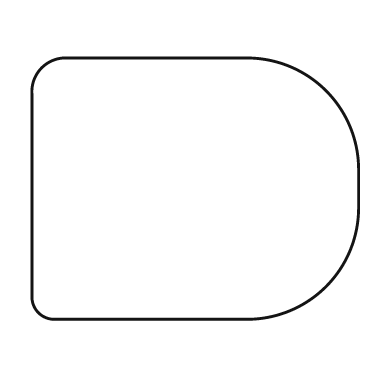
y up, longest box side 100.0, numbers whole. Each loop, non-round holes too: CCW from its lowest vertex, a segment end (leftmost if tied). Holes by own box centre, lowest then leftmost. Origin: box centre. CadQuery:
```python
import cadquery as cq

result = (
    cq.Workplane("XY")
    .moveTo(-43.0, -40.0)
    .lineTo(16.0, -40.0)
    .threePointArc((40.0, -30.0), (50.0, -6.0))
    .lineTo(50.0, 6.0)
    .threePointArc((40.0, 30.0), (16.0, 40.0))
    .lineTo(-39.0, 40.0)
    .threePointArc((-47.0, 37.0), (-50.0, 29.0))
    .lineTo(-50.0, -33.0)
    .threePointArc((-48.0, -38.0), (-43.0, -40.0))
    .close()
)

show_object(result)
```